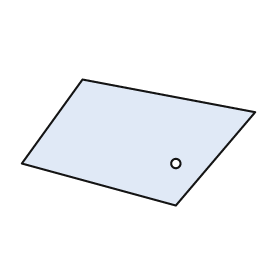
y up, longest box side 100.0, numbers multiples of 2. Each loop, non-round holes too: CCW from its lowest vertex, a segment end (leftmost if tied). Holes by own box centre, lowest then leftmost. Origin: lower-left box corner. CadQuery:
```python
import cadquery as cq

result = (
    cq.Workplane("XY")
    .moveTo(66.0, 0.0)
    .lineTo(100.0, 40.0)
    .lineTo(26.0, 54.0)
    .lineTo(0.0, 18.0)
    .close()
    .moveTo(66.0, 18.0)
    .circle(2.0)
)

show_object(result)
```